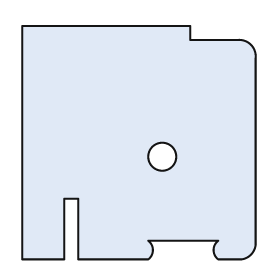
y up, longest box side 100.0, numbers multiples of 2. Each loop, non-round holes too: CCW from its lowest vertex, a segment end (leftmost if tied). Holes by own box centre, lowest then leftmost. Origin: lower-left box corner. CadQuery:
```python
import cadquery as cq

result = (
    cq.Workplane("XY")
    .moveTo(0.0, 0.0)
    .lineTo(18.0, 0.0)
    .lineTo(18.0, 26.0)
    .lineTo(24.0, 26.0)
    .lineTo(24.0, 0.0)
    .lineTo(54.0, 0.0)
    .threePointArc((56.0, 4.0), (54.0, 8.0))
    .lineTo(84.0, 8.0)
    .threePointArc((82.0, 4.0), (84.0, 0.0))
    .lineTo(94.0, 0.0)
    .threePointArc((98.0, 2.0), (100.0, 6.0))
    .lineTo(100.0, 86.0)
    .threePointArc((98.0, 92.0), (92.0, 94.0))
    .lineTo(72.0, 94.0)
    .lineTo(72.0, 100.0)
    .lineTo(0.0, 100.0)
    .close()
    .moveTo(60.0, 44.0)
    .circle(6.0)
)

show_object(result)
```